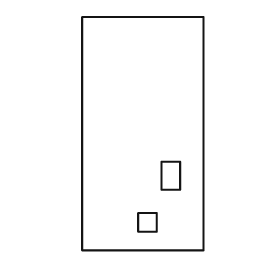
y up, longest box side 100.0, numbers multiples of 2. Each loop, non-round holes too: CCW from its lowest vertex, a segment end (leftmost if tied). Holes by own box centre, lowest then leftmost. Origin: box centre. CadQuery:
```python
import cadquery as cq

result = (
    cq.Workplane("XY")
    .moveTo(-26.0, -50.0)
    .lineTo(26.0, -50.0)
    .lineTo(26.0, 50.0)
    .lineTo(-26.0, 50.0)
    .close()
    .moveTo(-2.0, -42.0)
    .lineTo(6.0, -42.0)
    .lineTo(6.0, -34.0)
    .lineTo(-2.0, -34.0)
    .close()
    .moveTo(8.0, -24.0)
    .lineTo(16.0, -24.0)
    .lineTo(16.0, -12.0)
    .lineTo(8.0, -12.0)
    .close()
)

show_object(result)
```